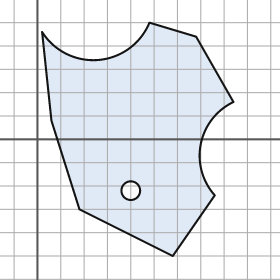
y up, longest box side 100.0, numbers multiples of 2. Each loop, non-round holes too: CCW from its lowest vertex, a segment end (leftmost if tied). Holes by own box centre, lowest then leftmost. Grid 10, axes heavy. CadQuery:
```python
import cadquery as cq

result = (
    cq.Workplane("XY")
    .moveTo(58.0, -50.0)
    .lineTo(76.0, -24.0)
    .threePointArc((70.0, -2.0), (84.0, 16.0))
    .lineTo(68.0, 44.0)
    .lineTo(48.0, 50.0)
    .threePointArc((26.0, 34.0), (2.0, 46.0))
    .lineTo(6.0, 8.0)
    .lineTo(18.0, -30.0)
    .close()
    .moveTo(40.0, -22.0)
    .circle(4.0)
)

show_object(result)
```